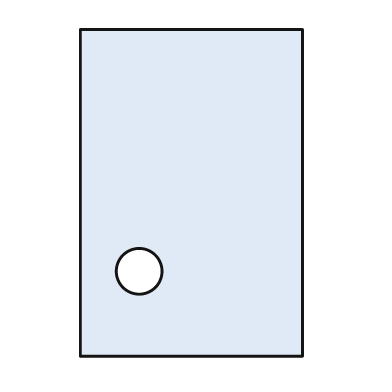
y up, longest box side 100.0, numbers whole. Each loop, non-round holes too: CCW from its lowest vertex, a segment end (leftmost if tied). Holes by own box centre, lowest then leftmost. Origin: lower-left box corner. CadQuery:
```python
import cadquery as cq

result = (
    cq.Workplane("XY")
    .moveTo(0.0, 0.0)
    .lineTo(68.0, 0.0)
    .lineTo(68.0, 100.0)
    .lineTo(0.0, 100.0)
    .close()
    .moveTo(18.0, 26.0)
    .circle(7.0)
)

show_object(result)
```